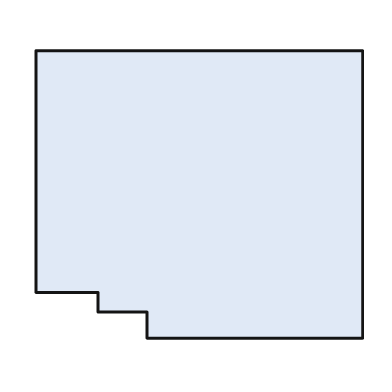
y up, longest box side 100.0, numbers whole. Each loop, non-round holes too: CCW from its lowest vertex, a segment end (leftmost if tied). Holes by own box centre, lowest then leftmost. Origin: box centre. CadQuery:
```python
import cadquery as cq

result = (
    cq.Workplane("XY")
    .moveTo(-16.0, -44.0)
    .lineTo(50.0, -44.0)
    .lineTo(50.0, 44.0)
    .lineTo(-50.0, 44.0)
    .lineTo(-50.0, -30.0)
    .lineTo(-31.0, -30.0)
    .lineTo(-31.0, -36.0)
    .lineTo(-16.0, -36.0)
    .close()
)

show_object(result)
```